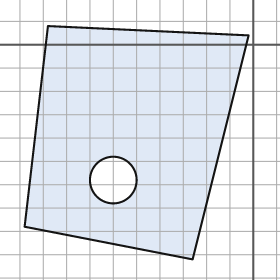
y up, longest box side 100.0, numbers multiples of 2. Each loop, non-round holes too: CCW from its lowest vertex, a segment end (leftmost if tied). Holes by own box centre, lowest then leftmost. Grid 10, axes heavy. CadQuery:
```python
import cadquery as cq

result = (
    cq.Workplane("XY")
    .moveTo(-26.0, -92.0)
    .lineTo(-2.0, 4.0)
    .lineTo(-88.0, 8.0)
    .lineTo(-98.0, -78.0)
    .close()
    .moveTo(-60.0, -58.0)
    .circle(10.0)
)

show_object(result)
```